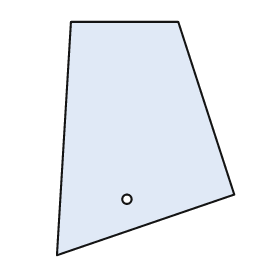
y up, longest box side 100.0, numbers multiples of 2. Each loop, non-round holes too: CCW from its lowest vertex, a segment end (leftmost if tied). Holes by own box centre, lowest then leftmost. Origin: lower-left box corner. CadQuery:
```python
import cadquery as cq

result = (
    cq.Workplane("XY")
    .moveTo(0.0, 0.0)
    .lineTo(76.0, 26.0)
    .lineTo(52.0, 100.0)
    .lineTo(6.0, 100.0)
    .close()
    .moveTo(30.0, 24.0)
    .circle(2.0)
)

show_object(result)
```